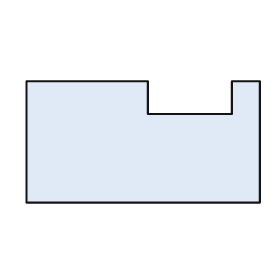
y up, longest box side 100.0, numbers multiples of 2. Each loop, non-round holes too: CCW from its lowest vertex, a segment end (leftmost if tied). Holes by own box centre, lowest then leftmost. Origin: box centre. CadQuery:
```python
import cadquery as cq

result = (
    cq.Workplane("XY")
    .moveTo(-50.0, -26.0)
    .lineTo(50.0, -26.0)
    .lineTo(50.0, 26.0)
    .lineTo(38.0, 26.0)
    .lineTo(38.0, 12.0)
    .lineTo(2.0, 12.0)
    .lineTo(2.0, 26.0)
    .lineTo(-50.0, 26.0)
    .close()
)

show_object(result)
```